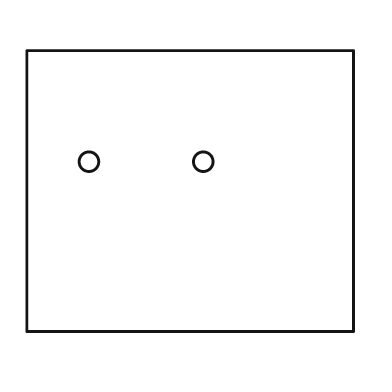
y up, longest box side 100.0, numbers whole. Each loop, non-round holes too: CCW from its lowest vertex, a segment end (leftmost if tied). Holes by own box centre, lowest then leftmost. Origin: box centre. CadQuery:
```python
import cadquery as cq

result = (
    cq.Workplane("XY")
    .moveTo(-50.0, -43.0)
    .lineTo(50.0, -43.0)
    .lineTo(50.0, 43.0)
    .lineTo(-50.0, 43.0)
    .close()
    .moveTo(-31.0, 9.0)
    .circle(3.0)
    .moveTo(4.0, 9.0)
    .circle(3.0)
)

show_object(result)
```